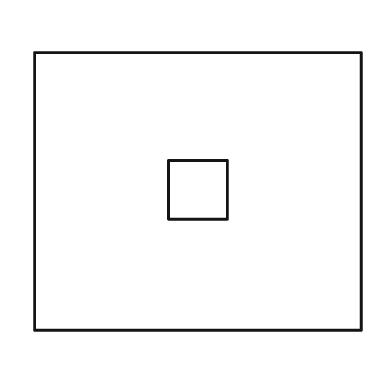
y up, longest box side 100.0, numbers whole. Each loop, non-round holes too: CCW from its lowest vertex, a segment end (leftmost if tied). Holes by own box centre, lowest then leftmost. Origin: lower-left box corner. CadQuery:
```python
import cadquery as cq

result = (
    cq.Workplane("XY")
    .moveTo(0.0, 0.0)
    .lineTo(100.0, 0.0)
    .lineTo(100.0, 85.0)
    .lineTo(0.0, 85.0)
    .close()
    .moveTo(41.0, 34.0)
    .lineTo(59.0, 34.0)
    .lineTo(59.0, 52.0)
    .lineTo(41.0, 52.0)
    .close()
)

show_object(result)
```